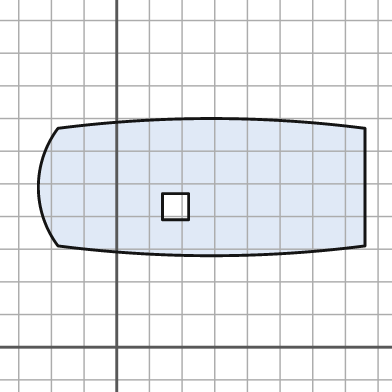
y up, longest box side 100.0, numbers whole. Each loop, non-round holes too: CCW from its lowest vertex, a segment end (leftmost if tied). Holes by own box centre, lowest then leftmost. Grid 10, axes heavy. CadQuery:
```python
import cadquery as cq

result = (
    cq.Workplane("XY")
    .moveTo(-18.0, 31.0)
    .threePointArc((29.0, 28.0), (76.0, 31.0))
    .lineTo(76.0, 67.0)
    .threePointArc((29.0, 70.0), (-18.0, 67.0))
    .threePointArc((-24.0, 49.0), (-18.0, 31.0))
    .close()
    .moveTo(14.0, 39.0)
    .lineTo(22.0, 39.0)
    .lineTo(22.0, 47.0)
    .lineTo(14.0, 47.0)
    .close()
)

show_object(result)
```